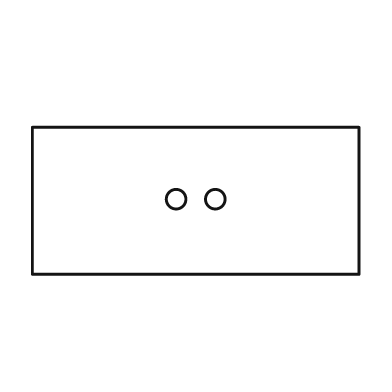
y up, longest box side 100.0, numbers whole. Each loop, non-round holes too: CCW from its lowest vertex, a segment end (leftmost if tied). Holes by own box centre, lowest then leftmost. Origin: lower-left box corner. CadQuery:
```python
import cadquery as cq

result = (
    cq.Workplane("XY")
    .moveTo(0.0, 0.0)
    .lineTo(100.0, 0.0)
    .lineTo(100.0, 45.0)
    .lineTo(0.0, 45.0)
    .close()
    .moveTo(44.0, 23.0)
    .circle(3.0)
    .moveTo(56.0, 23.0)
    .circle(3.0)
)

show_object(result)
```